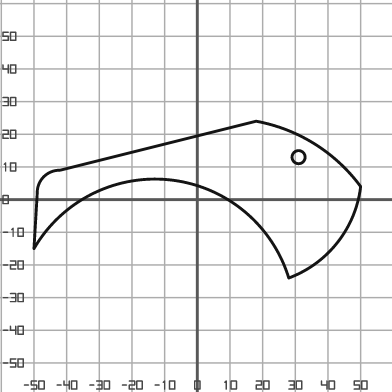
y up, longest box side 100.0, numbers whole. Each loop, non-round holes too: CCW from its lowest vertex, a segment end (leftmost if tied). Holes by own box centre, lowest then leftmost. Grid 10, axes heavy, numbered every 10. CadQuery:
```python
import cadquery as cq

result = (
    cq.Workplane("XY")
    .moveTo(28.0, -24.0)
    .threePointArc((43.0, -13.0), (50.0, 4.0))
    .threePointArc((36.0, 17.0), (18.0, 24.0))
    .lineTo(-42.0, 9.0)
    .threePointArc((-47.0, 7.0), (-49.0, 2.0))
    .lineTo(-50.0, -15.0)
    .threePointArc((-8.0, 6.0), (28.0, -24.0))
    .close()
    .moveTo(31.0, 13.0)
    .circle(2.0)
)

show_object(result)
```